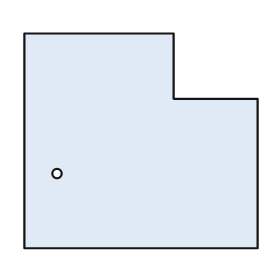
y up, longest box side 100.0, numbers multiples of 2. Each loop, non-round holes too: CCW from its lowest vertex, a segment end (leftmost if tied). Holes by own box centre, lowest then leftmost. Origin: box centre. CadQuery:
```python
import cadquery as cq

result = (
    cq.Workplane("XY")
    .moveTo(-50.0, -46.0)
    .lineTo(50.0, -46.0)
    .lineTo(50.0, 18.0)
    .lineTo(14.0, 18.0)
    .lineTo(14.0, 46.0)
    .lineTo(-50.0, 46.0)
    .close()
    .moveTo(-36.0, -14.0)
    .circle(2.0)
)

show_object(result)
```